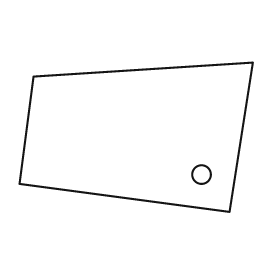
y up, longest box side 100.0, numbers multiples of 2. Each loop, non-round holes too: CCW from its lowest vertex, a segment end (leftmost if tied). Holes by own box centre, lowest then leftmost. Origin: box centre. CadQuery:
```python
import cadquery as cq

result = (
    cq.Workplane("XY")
    .moveTo(40.0, -32.0)
    .lineTo(50.0, 32.0)
    .lineTo(-44.0, 26.0)
    .lineTo(-50.0, -20.0)
    .close()
    .moveTo(28.0, -16.0)
    .circle(4.0)
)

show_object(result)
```